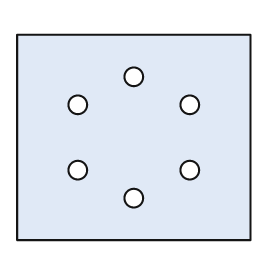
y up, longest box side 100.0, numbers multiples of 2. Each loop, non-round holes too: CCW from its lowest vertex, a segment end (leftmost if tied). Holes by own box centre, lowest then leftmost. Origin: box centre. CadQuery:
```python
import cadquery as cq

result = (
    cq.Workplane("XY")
    .moveTo(-50.0, -44.0)
    .lineTo(50.0, -44.0)
    .lineTo(50.0, 44.0)
    .lineTo(-50.0, 44.0)
    .close()
    .moveTo(0.0, -26.0)
    .circle(4.0)
    .moveTo(-24.0, -14.0)
    .circle(4.0)
    .moveTo(24.0, -14.0)
    .circle(4.0)
    .moveTo(-24.0, 14.0)
    .circle(4.0)
    .moveTo(24.0, 14.0)
    .circle(4.0)
    .moveTo(0.0, 26.0)
    .circle(4.0)
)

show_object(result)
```